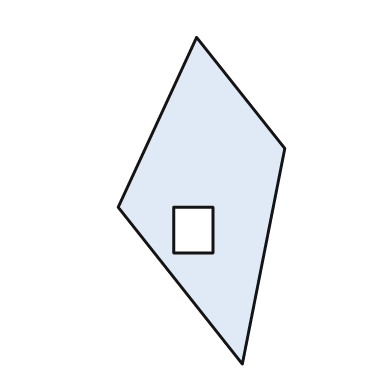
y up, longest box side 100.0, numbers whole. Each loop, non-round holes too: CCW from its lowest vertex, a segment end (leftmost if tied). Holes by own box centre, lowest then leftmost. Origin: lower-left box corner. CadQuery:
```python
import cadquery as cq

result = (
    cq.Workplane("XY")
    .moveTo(38.0, 0.0)
    .lineTo(51.0, 66.0)
    .lineTo(24.0, 100.0)
    .lineTo(0.0, 48.0)
    .close()
    .moveTo(17.0, 34.0)
    .lineTo(29.0, 34.0)
    .lineTo(29.0, 48.0)
    .lineTo(17.0, 48.0)
    .close()
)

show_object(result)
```